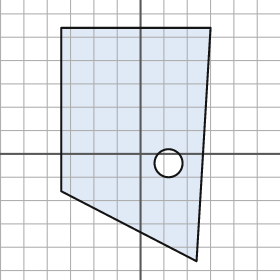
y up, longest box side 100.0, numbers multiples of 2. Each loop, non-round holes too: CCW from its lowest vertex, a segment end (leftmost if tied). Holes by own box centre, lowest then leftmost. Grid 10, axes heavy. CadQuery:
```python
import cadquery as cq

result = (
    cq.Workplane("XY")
    .moveTo(24.0, -46.0)
    .lineTo(30.0, 54.0)
    .lineTo(-34.0, 54.0)
    .lineTo(-34.0, -16.0)
    .close()
    .moveTo(12.0, -4.0)
    .circle(6.0)
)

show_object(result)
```